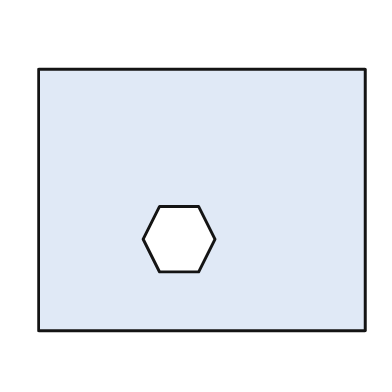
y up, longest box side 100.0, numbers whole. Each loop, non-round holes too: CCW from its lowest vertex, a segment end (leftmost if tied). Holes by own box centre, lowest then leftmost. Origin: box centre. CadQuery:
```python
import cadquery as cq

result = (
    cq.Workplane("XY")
    .moveTo(-50.0, -40.0)
    .lineTo(50.0, -40.0)
    .lineTo(50.0, 40.0)
    .lineTo(-50.0, 40.0)
    .close()
    .moveTo(-13.0, -22.0)
    .lineTo(-1.0, -22.0)
    .lineTo(4.0, -12.0)
    .lineTo(-1.0, -2.0)
    .lineTo(-13.0, -2.0)
    .lineTo(-18.0, -12.0)
    .close()
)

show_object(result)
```